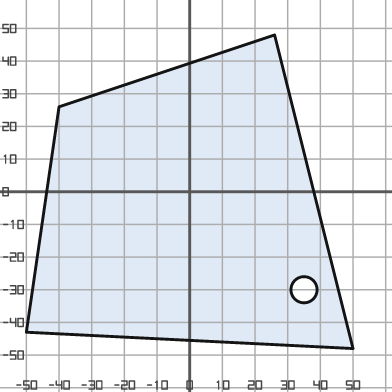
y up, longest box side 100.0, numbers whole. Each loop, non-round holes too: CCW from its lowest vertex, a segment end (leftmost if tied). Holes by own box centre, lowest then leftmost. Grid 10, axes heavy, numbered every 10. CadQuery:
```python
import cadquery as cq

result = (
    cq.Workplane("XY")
    .moveTo(50.0, -48.0)
    .lineTo(26.0, 48.0)
    .lineTo(-40.0, 26.0)
    .lineTo(-50.0, -43.0)
    .close()
    .moveTo(35.0, -30.0)
    .circle(4.0)
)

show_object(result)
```